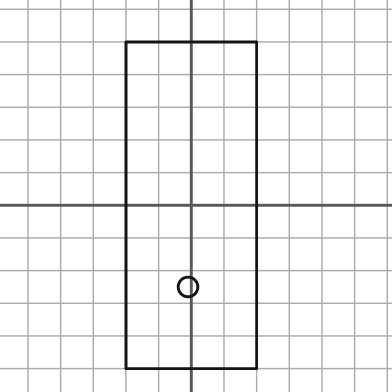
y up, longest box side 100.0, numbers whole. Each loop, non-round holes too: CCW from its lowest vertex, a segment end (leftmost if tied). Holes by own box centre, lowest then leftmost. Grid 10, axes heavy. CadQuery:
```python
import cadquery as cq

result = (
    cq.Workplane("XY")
    .moveTo(-20.0, -50.0)
    .lineTo(20.0, -50.0)
    .lineTo(20.0, 50.0)
    .lineTo(-20.0, 50.0)
    .close()
    .moveTo(-1.0, -25.0)
    .circle(3.0)
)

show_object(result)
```